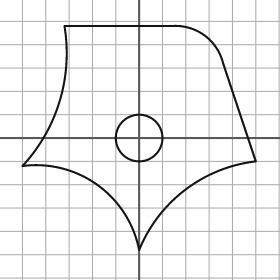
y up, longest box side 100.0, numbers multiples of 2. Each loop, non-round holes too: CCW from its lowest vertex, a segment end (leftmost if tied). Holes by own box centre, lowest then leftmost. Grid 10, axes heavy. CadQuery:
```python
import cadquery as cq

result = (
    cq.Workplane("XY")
    .moveTo(0.0, -48.0)
    .threePointArc((20.0, -22.0), (50.0, -10.0))
    .lineTo(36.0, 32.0)
    .threePointArc((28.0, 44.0), (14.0, 48.0))
    .lineTo(-32.0, 48.0)
    .threePointArc((-34.0, 16.0), (-50.0, -12.0))
    .threePointArc((-18.0, -20.0), (0.0, -48.0))
    .close()
    .moveTo(0.0, 0.0)
    .circle(10.0)
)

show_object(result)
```